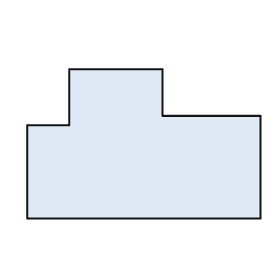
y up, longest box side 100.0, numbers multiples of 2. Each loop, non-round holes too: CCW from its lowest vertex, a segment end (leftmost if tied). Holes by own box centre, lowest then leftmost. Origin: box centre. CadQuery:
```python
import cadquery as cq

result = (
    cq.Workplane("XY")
    .moveTo(-50.0, -32.0)
    .lineTo(50.0, -32.0)
    .lineTo(50.0, 12.0)
    .lineTo(8.0, 12.0)
    .lineTo(8.0, 32.0)
    .lineTo(-32.0, 32.0)
    .lineTo(-32.0, 8.0)
    .lineTo(-50.0, 8.0)
    .close()
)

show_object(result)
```